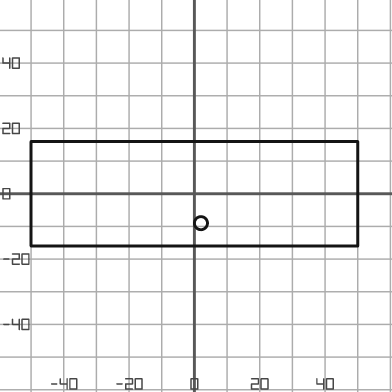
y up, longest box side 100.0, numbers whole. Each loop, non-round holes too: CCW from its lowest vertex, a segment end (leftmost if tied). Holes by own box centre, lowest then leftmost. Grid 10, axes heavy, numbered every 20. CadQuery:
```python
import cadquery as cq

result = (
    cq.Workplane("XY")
    .moveTo(-50.0, -16.0)
    .lineTo(50.0, -16.0)
    .lineTo(50.0, 16.0)
    .lineTo(-50.0, 16.0)
    .close()
    .moveTo(2.0, -9.0)
    .circle(2.0)
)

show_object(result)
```